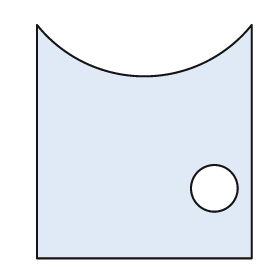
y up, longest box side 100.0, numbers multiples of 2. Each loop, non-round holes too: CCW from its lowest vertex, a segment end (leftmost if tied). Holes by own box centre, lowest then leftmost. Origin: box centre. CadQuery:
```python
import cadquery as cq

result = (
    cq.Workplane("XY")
    .moveTo(-46.0, -50.0)
    .lineTo(46.0, -50.0)
    .lineTo(46.0, 50.0)
    .threePointArc((0.0, 28.0), (-46.0, 50.0))
    .close()
    .moveTo(30.0, -20.0)
    .circle(10.0)
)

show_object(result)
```